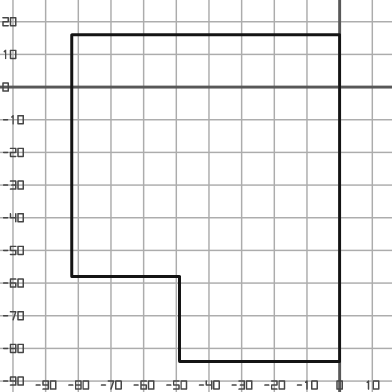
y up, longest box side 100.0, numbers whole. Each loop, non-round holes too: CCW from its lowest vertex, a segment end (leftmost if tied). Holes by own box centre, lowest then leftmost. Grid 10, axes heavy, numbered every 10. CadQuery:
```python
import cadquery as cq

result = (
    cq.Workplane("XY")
    .moveTo(-49.0, -84.0)
    .lineTo(0.0, -84.0)
    .lineTo(0.0, 16.0)
    .lineTo(-82.0, 16.0)
    .lineTo(-82.0, -58.0)
    .lineTo(-49.0, -58.0)
    .close()
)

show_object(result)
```